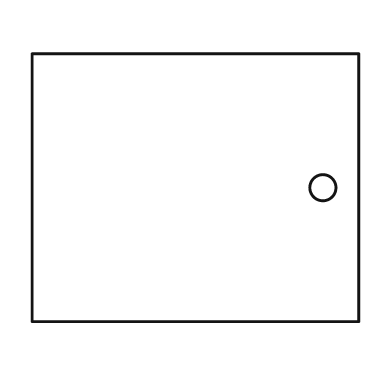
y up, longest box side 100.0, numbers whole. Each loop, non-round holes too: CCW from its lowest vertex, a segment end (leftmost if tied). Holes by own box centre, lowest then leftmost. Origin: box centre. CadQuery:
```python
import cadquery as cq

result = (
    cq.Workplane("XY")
    .moveTo(-50.0, -41.0)
    .lineTo(50.0, -41.0)
    .lineTo(50.0, 41.0)
    .lineTo(-50.0, 41.0)
    .close()
    .moveTo(39.0, 0.0)
    .circle(4.0)
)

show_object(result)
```